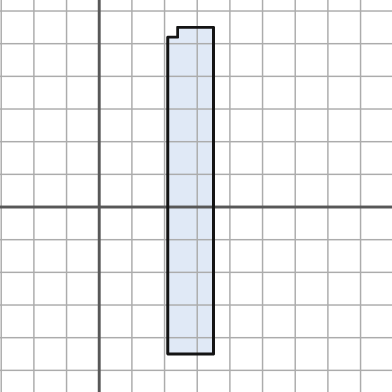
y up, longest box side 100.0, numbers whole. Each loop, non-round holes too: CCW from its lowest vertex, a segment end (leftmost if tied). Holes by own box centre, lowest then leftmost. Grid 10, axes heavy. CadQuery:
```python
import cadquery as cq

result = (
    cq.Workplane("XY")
    .moveTo(21.0, -45.0)
    .lineTo(35.0, -45.0)
    .lineTo(35.0, 55.0)
    .lineTo(24.0, 55.0)
    .lineTo(24.0, 52.0)
    .lineTo(21.0, 52.0)
    .close()
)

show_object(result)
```